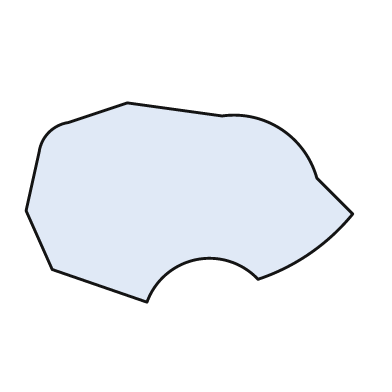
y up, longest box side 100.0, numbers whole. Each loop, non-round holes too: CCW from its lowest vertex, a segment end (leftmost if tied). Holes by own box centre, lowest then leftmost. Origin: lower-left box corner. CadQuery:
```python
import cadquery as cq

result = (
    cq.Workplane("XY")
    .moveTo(37.0, 0.0)
    .threePointArc((52.0, 13.0), (71.0, 7.0))
    .threePointArc((87.0, 15.0), (100.0, 27.0))
    .lineTo(89.0, 38.0)
    .threePointArc((78.0, 53.0), (60.0, 57.0))
    .lineTo(31.0, 61.0)
    .lineTo(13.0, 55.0)
    .threePointArc((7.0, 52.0), (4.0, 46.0))
    .lineTo(0.0, 28.0)
    .lineTo(8.0, 10.0)
    .close()
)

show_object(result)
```